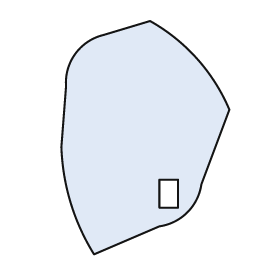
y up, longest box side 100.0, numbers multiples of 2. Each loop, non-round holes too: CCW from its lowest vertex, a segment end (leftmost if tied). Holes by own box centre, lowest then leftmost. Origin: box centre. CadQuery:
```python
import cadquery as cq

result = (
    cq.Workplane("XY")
    .moveTo(-22.0, -50.0)
    .lineTo(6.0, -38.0)
    .threePointArc((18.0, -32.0), (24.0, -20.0))
    .lineTo(36.0, 12.0)
    .threePointArc((22.0, 34.0), (2.0, 50.0))
    .lineTo(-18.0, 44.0)
    .threePointArc((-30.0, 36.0), (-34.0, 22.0))
    .lineTo(-36.0, -4.0)
    .threePointArc((-32.0, -28.0), (-22.0, -50.0))
    .close()
    .moveTo(6.0, -30.0)
    .lineTo(14.0, -30.0)
    .lineTo(14.0, -18.0)
    .lineTo(6.0, -18.0)
    .close()
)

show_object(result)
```